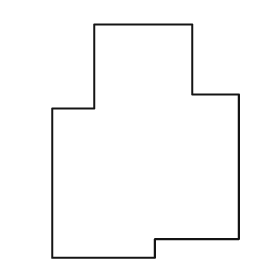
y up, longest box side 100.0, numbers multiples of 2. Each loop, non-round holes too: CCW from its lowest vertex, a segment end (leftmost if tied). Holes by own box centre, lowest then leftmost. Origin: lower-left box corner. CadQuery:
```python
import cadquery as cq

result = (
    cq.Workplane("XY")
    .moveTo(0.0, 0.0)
    .lineTo(44.0, 0.0)
    .lineTo(44.0, 8.0)
    .lineTo(80.0, 8.0)
    .lineTo(80.0, 70.0)
    .lineTo(60.0, 70.0)
    .lineTo(60.0, 100.0)
    .lineTo(18.0, 100.0)
    .lineTo(18.0, 64.0)
    .lineTo(0.0, 64.0)
    .close()
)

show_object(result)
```